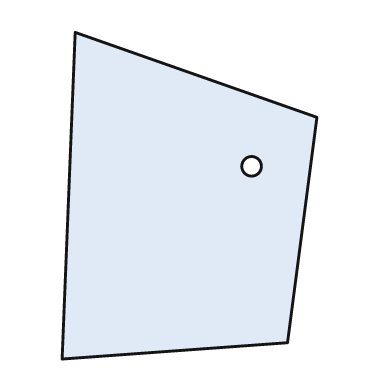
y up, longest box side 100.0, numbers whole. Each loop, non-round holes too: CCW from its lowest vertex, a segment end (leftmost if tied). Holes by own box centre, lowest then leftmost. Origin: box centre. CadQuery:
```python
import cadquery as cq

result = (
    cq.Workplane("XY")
    .moveTo(-39.0, -50.0)
    .lineTo(30.0, -45.0)
    .lineTo(39.0, 24.0)
    .lineTo(-35.0, 50.0)
    .close()
    .moveTo(19.0, 9.0)
    .circle(3.0)
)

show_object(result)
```